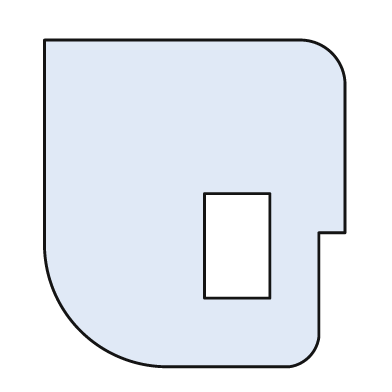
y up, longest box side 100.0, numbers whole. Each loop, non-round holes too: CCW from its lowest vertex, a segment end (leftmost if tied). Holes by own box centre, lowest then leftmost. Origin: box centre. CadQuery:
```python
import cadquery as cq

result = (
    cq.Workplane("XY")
    .moveTo(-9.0, -50.0)
    .lineTo(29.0, -50.0)
    .threePointArc((35.0, -47.0), (38.0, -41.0))
    .lineTo(38.0, -9.0)
    .lineTo(46.0, -9.0)
    .lineTo(46.0, 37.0)
    .threePointArc((42.0, 46.0), (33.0, 50.0))
    .lineTo(-46.0, 50.0)
    .lineTo(-46.0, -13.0)
    .threePointArc((-35.0, -39.0), (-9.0, -50.0))
    .close()
    .moveTo(3.0, -29.0)
    .lineTo(23.0, -29.0)
    .lineTo(23.0, 3.0)
    .lineTo(3.0, 3.0)
    .close()
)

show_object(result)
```